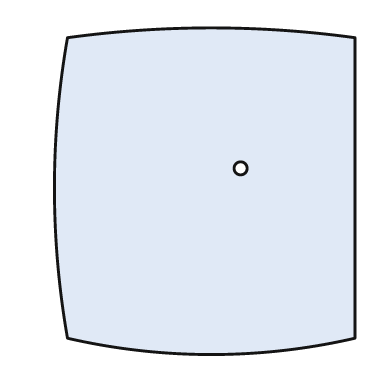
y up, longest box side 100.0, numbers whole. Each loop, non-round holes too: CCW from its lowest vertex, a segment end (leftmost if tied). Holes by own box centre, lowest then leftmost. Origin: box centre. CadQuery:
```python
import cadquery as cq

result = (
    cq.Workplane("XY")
    .moveTo(-42.0, -45.0)
    .threePointArc((2.0, -50.0), (46.0, -45.0))
    .lineTo(46.0, 47.0)
    .threePointArc((2.0, 50.0), (-42.0, 47.0))
    .threePointArc((-46.0, 1.0), (-42.0, -45.0))
    .close()
    .moveTo(11.0, 7.0)
    .circle(2.0)
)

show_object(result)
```